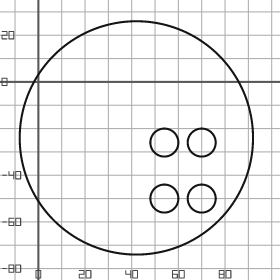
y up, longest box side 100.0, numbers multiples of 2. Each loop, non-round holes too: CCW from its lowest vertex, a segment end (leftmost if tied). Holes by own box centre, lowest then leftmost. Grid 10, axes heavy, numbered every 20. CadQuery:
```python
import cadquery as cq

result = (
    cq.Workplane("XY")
    .moveTo(42.0, -24.0)
    .circle(50.0)
    .moveTo(54.0, -50.0)
    .circle(6.0)
    .moveTo(70.0, -50.0)
    .circle(6.0)
    .moveTo(54.0, -26.0)
    .circle(6.0)
    .moveTo(70.0, -26.0)
    .circle(6.0)
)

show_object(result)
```